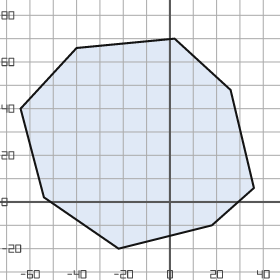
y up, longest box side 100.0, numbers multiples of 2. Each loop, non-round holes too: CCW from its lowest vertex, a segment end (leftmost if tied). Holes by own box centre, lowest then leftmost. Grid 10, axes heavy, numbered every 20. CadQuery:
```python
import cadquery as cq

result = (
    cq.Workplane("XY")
    .moveTo(-22.0, -20.0)
    .lineTo(18.0, -10.0)
    .lineTo(36.0, 6.0)
    .lineTo(26.0, 48.0)
    .lineTo(2.0, 70.0)
    .lineTo(-40.0, 66.0)
    .lineTo(-64.0, 40.0)
    .lineTo(-54.0, 2.0)
    .close()
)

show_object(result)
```